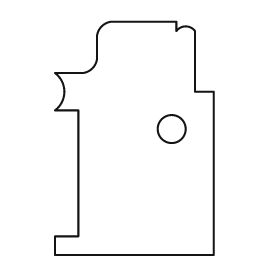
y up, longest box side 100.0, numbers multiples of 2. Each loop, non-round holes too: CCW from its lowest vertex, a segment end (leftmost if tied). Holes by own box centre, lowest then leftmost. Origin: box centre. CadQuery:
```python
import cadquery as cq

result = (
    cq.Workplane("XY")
    .moveTo(-34.0, -50.0)
    .lineTo(34.0, -50.0)
    .lineTo(34.0, 20.0)
    .lineTo(26.0, 20.0)
    .lineTo(26.0, 46.0)
    .threePointArc((22.0, 48.0), (18.0, 46.0))
    .lineTo(18.0, 50.0)
    .lineTo(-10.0, 50.0)
    .threePointArc((-14.0, 48.0), (-16.0, 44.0))
    .lineTo(-16.0, 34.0)
    .threePointArc((-18.0, 30.0), (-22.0, 28.0))
    .lineTo(-34.0, 28.0)
    .threePointArc((-30.0, 20.0), (-34.0, 12.0))
    .lineTo(-24.0, 12.0)
    .lineTo(-24.0, -42.0)
    .lineTo(-34.0, -42.0)
    .close()
    .moveTo(16.0, 4.0)
    .circle(6.0)
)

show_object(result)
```